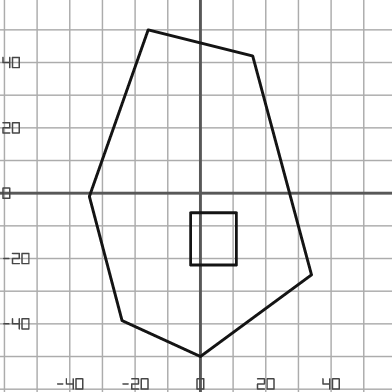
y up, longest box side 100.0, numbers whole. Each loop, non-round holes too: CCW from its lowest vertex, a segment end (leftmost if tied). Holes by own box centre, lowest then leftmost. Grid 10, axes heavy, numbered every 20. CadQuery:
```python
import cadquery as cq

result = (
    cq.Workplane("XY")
    .moveTo(0.0, -50.0)
    .lineTo(34.0, -25.0)
    .lineTo(16.0, 42.0)
    .lineTo(-16.0, 50.0)
    .lineTo(-34.0, -1.0)
    .lineTo(-24.0, -39.0)
    .close()
    .moveTo(-3.0, -22.0)
    .lineTo(11.0, -22.0)
    .lineTo(11.0, -6.0)
    .lineTo(-3.0, -6.0)
    .close()
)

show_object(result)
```